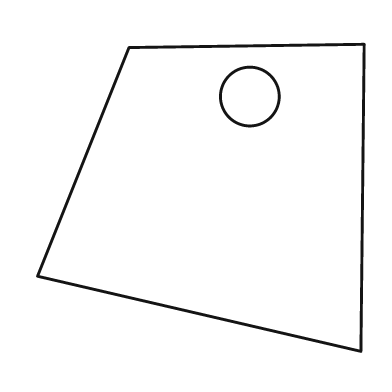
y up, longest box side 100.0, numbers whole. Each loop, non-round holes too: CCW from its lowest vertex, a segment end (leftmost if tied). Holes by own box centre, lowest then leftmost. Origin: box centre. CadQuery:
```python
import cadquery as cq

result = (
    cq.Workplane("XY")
    .moveTo(49.0, -47.0)
    .lineTo(50.0, 47.0)
    .lineTo(-22.0, 46.0)
    .lineTo(-50.0, -24.0)
    .close()
    .moveTo(15.0, 31.0)
    .circle(9.0)
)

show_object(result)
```